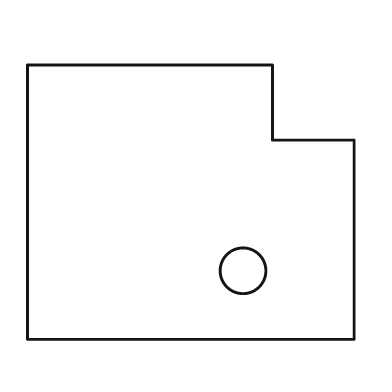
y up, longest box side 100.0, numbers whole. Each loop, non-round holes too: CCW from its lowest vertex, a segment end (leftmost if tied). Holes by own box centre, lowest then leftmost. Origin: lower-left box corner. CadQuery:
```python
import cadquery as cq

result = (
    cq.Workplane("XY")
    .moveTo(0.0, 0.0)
    .lineTo(100.0, 0.0)
    .lineTo(100.0, 61.0)
    .lineTo(75.0, 61.0)
    .lineTo(75.0, 84.0)
    .lineTo(0.0, 84.0)
    .close()
    .moveTo(66.0, 21.0)
    .circle(7.0)
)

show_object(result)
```